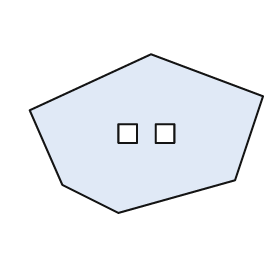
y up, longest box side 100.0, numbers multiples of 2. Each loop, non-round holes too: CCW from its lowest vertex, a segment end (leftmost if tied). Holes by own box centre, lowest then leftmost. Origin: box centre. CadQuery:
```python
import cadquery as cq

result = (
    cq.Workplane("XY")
    .moveTo(-12.0, -34.0)
    .lineTo(38.0, -20.0)
    .lineTo(50.0, 16.0)
    .lineTo(2.0, 34.0)
    .lineTo(-50.0, 10.0)
    .lineTo(-36.0, -22.0)
    .close()
    .moveTo(-12.0, -4.0)
    .lineTo(-4.0, -4.0)
    .lineTo(-4.0, 4.0)
    .lineTo(-12.0, 4.0)
    .close()
    .moveTo(4.0, -4.0)
    .lineTo(12.0, -4.0)
    .lineTo(12.0, 4.0)
    .lineTo(4.0, 4.0)
    .close()
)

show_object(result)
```